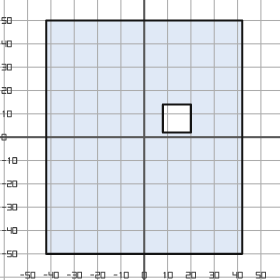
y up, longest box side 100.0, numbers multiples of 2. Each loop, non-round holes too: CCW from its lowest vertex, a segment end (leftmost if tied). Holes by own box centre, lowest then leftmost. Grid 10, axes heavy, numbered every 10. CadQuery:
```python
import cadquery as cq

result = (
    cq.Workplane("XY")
    .moveTo(-42.0, -50.0)
    .lineTo(42.0, -50.0)
    .lineTo(42.0, 50.0)
    .lineTo(-42.0, 50.0)
    .close()
    .moveTo(8.0, 2.0)
    .lineTo(20.0, 2.0)
    .lineTo(20.0, 14.0)
    .lineTo(8.0, 14.0)
    .close()
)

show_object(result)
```